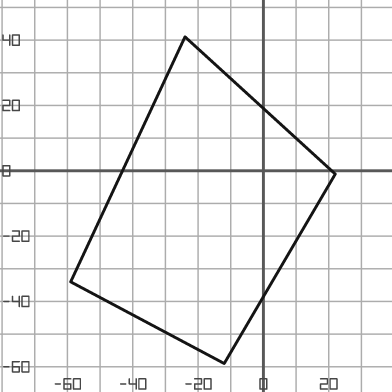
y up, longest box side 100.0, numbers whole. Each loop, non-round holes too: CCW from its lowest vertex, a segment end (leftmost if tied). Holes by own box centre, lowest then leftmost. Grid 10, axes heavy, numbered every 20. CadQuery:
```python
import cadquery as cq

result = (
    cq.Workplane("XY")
    .moveTo(-12.0, -59.0)
    .lineTo(22.0, -1.0)
    .lineTo(-24.0, 41.0)
    .lineTo(-59.0, -34.0)
    .close()
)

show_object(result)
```